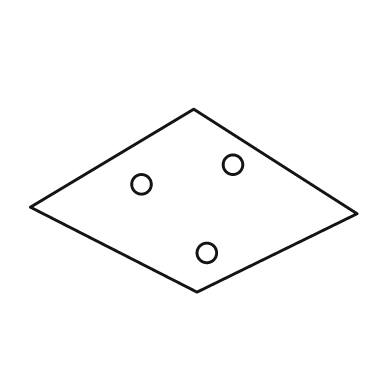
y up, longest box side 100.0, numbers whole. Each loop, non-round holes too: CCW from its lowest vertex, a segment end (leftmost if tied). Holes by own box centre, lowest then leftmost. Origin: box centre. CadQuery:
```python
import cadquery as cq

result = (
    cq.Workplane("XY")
    .moveTo(1.0, -28.0)
    .lineTo(50.0, -4.0)
    .lineTo(0.0, 28.0)
    .lineTo(-50.0, -2.0)
    .close()
    .moveTo(4.0, -16.0)
    .circle(3.0)
    .moveTo(-16.0, 5.0)
    .circle(3.0)
    .moveTo(12.0, 11.0)
    .circle(3.0)
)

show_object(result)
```